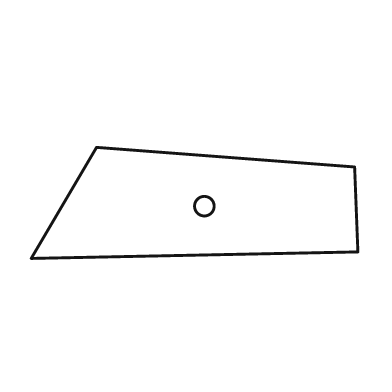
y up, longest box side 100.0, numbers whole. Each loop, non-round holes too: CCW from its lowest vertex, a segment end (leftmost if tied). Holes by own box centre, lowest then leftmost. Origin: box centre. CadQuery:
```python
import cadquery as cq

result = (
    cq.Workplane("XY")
    .moveTo(-50.0, -17.0)
    .lineTo(50.0, -15.0)
    .lineTo(49.0, 11.0)
    .lineTo(-30.0, 17.0)
    .close()
    .moveTo(3.0, -1.0)
    .circle(3.0)
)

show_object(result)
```